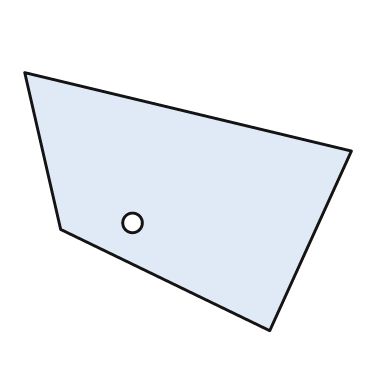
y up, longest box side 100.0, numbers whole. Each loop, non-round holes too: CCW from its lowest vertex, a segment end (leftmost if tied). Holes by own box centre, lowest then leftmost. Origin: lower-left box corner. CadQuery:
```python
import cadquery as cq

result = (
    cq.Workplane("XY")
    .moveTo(75.0, 0.0)
    .lineTo(100.0, 55.0)
    .lineTo(0.0, 79.0)
    .lineTo(11.0, 31.0)
    .close()
    .moveTo(33.0, 33.0)
    .circle(3.0)
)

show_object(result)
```